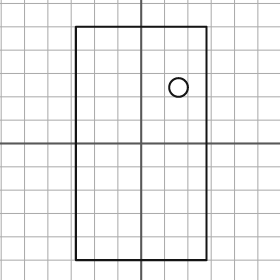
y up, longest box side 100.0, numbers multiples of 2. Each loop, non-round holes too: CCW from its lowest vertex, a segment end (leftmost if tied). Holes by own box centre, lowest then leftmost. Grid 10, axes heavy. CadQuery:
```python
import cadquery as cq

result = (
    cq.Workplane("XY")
    .moveTo(-28.0, -50.0)
    .lineTo(28.0, -50.0)
    .lineTo(28.0, 50.0)
    .lineTo(-28.0, 50.0)
    .close()
    .moveTo(16.0, 24.0)
    .circle(4.0)
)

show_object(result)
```